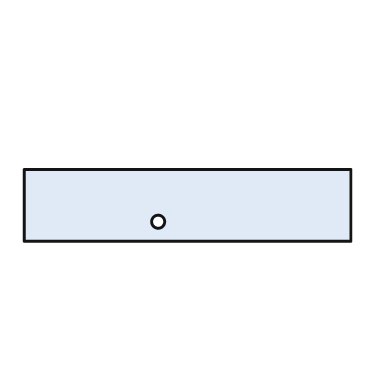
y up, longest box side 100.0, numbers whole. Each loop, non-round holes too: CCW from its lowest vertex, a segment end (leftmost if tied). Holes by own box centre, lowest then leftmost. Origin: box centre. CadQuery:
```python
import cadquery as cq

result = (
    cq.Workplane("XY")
    .moveTo(-50.0, -11.0)
    .lineTo(50.0, -11.0)
    .lineTo(50.0, 11.0)
    .lineTo(-50.0, 11.0)
    .close()
    .moveTo(-9.0, -5.0)
    .circle(2.0)
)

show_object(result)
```